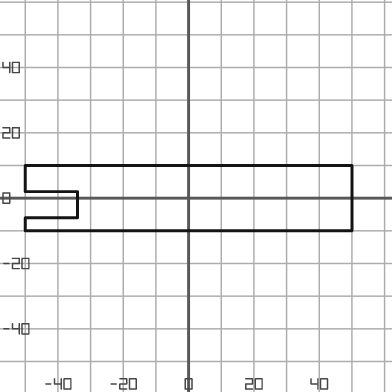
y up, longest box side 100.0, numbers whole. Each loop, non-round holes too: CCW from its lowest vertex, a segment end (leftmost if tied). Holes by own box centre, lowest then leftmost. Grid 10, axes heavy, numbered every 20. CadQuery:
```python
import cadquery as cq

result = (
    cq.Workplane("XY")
    .moveTo(-50.0, -10.0)
    .lineTo(50.0, -10.0)
    .lineTo(50.0, 10.0)
    .lineTo(-50.0, 10.0)
    .lineTo(-50.0, 2.0)
    .lineTo(-34.0, 2.0)
    .lineTo(-34.0, -6.0)
    .lineTo(-50.0, -6.0)
    .close()
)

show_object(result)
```